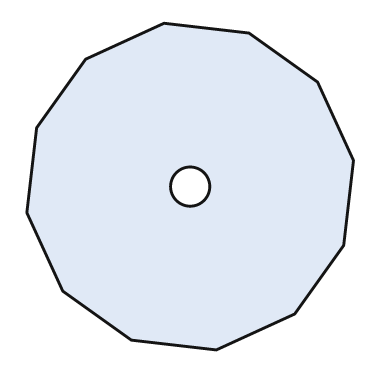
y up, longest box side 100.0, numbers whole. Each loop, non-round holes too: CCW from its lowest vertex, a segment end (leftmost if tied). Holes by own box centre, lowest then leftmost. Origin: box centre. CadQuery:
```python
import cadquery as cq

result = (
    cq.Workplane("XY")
    .moveTo(8.0, -50.0)
    .lineTo(32.0, -39.0)
    .lineTo(47.0, -18.0)
    .lineTo(50.0, 8.0)
    .lineTo(39.0, 32.0)
    .lineTo(18.0, 47.0)
    .lineTo(-8.0, 50.0)
    .lineTo(-32.0, 39.0)
    .lineTo(-47.0, 18.0)
    .lineTo(-50.0, -8.0)
    .lineTo(-39.0, -32.0)
    .lineTo(-18.0, -47.0)
    .close()
    .moveTo(0.0, 0.0)
    .circle(6.0)
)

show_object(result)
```